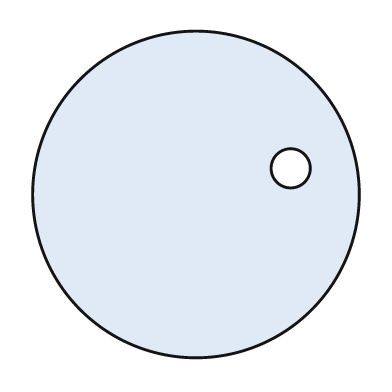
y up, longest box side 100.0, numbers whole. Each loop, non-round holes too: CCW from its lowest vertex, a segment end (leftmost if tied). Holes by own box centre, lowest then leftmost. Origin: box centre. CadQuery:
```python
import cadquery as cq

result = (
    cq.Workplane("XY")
    .moveTo(0.0, 0.0)
    .circle(50.0)
    .moveTo(29.0, 8.0)
    .circle(6.0)
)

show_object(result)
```